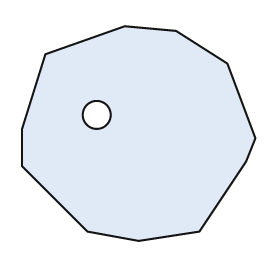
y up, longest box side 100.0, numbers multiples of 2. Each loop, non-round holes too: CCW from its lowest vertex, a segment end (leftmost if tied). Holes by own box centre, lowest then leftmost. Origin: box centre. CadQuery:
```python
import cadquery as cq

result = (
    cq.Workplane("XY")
    .moveTo(0.0, -46.0)
    .lineTo(26.0, -42.0)
    .lineTo(46.0, -12.0)
    .lineTo(50.0, -2.0)
    .lineTo(38.0, 30.0)
    .lineTo(16.0, 44.0)
    .lineTo(-6.0, 46.0)
    .lineTo(-40.0, 34.0)
    .lineTo(-50.0, 2.0)
    .lineTo(-50.0, -14.0)
    .lineTo(-22.0, -42.0)
    .close()
    .moveTo(-18.0, 8.0)
    .circle(6.0)
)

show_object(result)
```